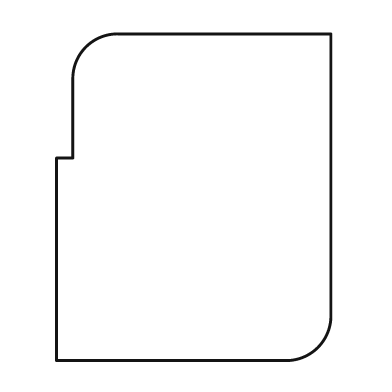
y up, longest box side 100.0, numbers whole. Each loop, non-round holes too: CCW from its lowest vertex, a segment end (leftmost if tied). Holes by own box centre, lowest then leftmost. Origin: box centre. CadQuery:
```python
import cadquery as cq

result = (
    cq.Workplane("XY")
    .moveTo(-42.0, -50.0)
    .lineTo(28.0, -50.0)
    .threePointArc((38.0, -46.0), (42.0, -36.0))
    .lineTo(42.0, 50.0)
    .lineTo(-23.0, 50.0)
    .threePointArc((-33.0, 46.0), (-37.0, 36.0))
    .lineTo(-37.0, 12.0)
    .lineTo(-42.0, 12.0)
    .close()
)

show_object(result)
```